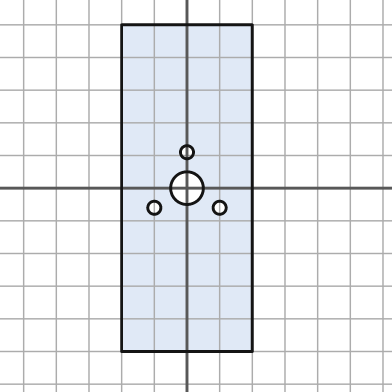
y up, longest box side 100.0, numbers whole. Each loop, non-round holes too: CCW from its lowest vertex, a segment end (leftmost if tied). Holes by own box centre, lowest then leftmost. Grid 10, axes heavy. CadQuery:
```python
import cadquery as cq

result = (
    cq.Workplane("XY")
    .moveTo(-20.0, -50.0)
    .lineTo(20.0, -50.0)
    .lineTo(20.0, 50.0)
    .lineTo(-20.0, 50.0)
    .close()
    .moveTo(-10.0, -6.0)
    .circle(2.0)
    .moveTo(10.0, -6.0)
    .circle(2.0)
    .moveTo(0.0, 0.0)
    .circle(5.0)
    .moveTo(0.0, 11.0)
    .circle(2.0)
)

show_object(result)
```